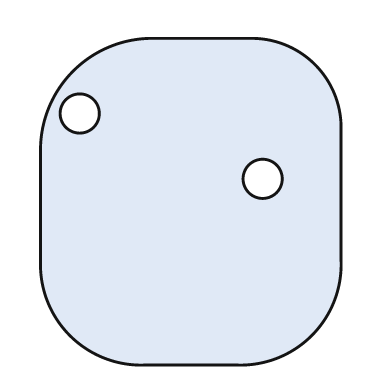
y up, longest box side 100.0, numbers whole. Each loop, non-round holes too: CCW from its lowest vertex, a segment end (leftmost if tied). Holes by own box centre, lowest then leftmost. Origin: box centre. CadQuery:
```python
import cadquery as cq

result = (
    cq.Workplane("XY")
    .moveTo(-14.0, -50.0)
    .lineTo(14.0, -50.0)
    .threePointArc((37.0, -41.0), (46.0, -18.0))
    .lineTo(46.0, 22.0)
    .threePointArc((38.0, 42.0), (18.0, 50.0))
    .lineTo(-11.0, 50.0)
    .threePointArc((-36.0, 40.0), (-46.0, 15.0))
    .lineTo(-46.0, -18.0)
    .threePointArc((-37.0, -41.0), (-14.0, -50.0))
    .close()
    .moveTo(22.0, 7.0)
    .circle(6.0)
    .moveTo(-34.0, 27.0)
    .circle(6.0)
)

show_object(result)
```